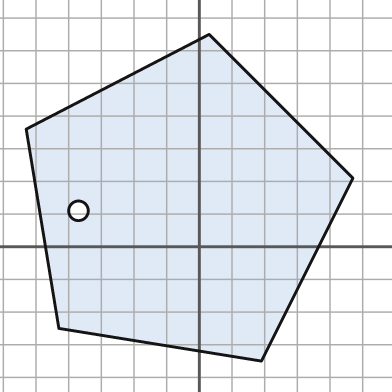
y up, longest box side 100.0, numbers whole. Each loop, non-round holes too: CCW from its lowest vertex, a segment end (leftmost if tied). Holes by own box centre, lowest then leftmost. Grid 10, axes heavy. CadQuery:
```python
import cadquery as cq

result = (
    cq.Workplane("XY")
    .moveTo(19.0, -35.0)
    .lineTo(47.0, 21.0)
    .lineTo(3.0, 65.0)
    .lineTo(-53.0, 36.0)
    .lineTo(-43.0, -25.0)
    .close()
    .moveTo(-37.0, 11.0)
    .circle(3.0)
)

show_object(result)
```